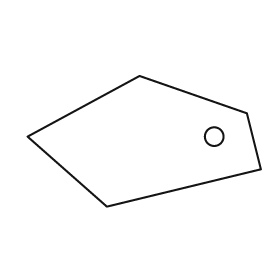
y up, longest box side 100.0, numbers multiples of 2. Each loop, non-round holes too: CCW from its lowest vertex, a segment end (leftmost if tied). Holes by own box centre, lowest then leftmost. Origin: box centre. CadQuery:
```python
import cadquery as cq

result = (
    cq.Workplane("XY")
    .moveTo(-16.0, -28.0)
    .lineTo(50.0, -12.0)
    .lineTo(44.0, 12.0)
    .lineTo(-2.0, 28.0)
    .lineTo(-50.0, 2.0)
    .close()
    .moveTo(30.0, 2.0)
    .circle(4.0)
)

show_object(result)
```